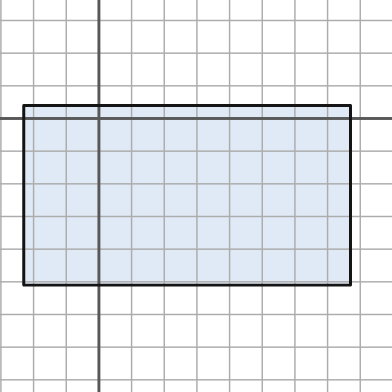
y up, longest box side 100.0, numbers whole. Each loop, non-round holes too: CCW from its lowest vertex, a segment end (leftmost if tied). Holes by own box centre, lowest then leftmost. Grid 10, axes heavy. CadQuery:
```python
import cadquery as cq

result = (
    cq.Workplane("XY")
    .moveTo(-23.0, -51.0)
    .lineTo(77.0, -51.0)
    .lineTo(77.0, 4.0)
    .lineTo(-23.0, 4.0)
    .close()
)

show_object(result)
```